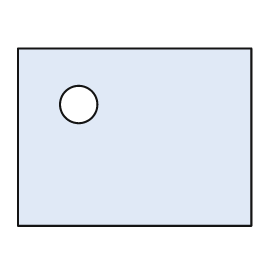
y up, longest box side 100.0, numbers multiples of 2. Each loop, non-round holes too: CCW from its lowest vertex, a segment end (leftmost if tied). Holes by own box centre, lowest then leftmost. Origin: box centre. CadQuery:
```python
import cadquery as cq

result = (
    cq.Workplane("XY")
    .moveTo(-50.0, -38.0)
    .lineTo(50.0, -38.0)
    .lineTo(50.0, 38.0)
    .lineTo(-50.0, 38.0)
    .close()
    .moveTo(-24.0, 14.0)
    .circle(8.0)
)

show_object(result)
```